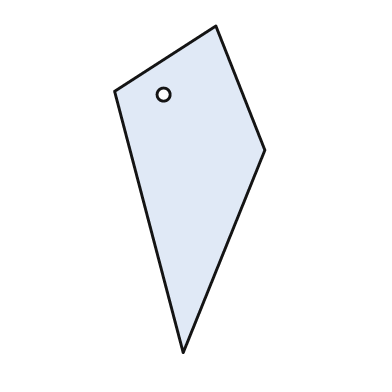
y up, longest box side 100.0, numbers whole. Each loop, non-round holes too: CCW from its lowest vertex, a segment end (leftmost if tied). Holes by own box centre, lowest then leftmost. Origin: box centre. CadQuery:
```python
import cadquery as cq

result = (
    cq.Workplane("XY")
    .moveTo(-2.0, -50.0)
    .lineTo(23.0, 12.0)
    .lineTo(8.0, 50.0)
    .lineTo(-23.0, 30.0)
    .close()
    .moveTo(-8.0, 29.0)
    .circle(2.0)
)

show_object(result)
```